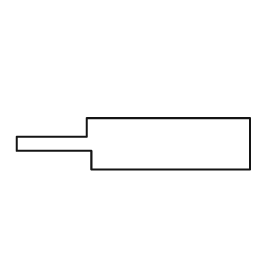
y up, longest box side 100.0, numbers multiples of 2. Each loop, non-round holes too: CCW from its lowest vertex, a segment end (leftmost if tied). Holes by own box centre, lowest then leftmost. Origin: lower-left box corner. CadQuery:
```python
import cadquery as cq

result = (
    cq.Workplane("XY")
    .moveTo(32.0, 0.0)
    .lineTo(100.0, 0.0)
    .lineTo(100.0, 22.0)
    .lineTo(30.0, 22.0)
    .lineTo(30.0, 14.0)
    .lineTo(0.0, 14.0)
    .lineTo(0.0, 8.0)
    .lineTo(32.0, 8.0)
    .close()
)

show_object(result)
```